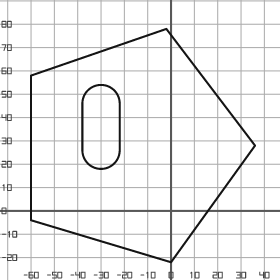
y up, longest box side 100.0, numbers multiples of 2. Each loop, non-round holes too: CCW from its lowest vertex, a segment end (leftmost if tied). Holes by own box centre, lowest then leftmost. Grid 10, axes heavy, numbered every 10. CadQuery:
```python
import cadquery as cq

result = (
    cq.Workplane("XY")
    .moveTo(0.0, -22.0)
    .lineTo(36.0, 28.0)
    .lineTo(-2.0, 78.0)
    .lineTo(-60.0, 58.0)
    .lineTo(-60.0, -4.0)
    .close()
    .moveTo(-38.0, 26.0)
    .threePointArc((-30.0, 18.0), (-22.0, 26.0))
    .lineTo(-22.0, 46.0)
    .threePointArc((-30.0, 54.0), (-38.0, 46.0))
    .close()
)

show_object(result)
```